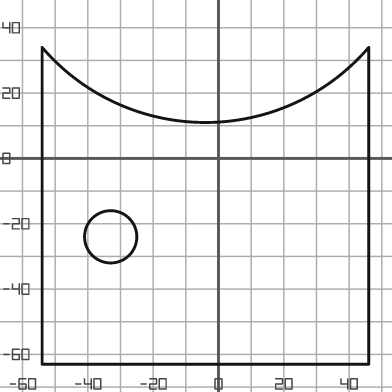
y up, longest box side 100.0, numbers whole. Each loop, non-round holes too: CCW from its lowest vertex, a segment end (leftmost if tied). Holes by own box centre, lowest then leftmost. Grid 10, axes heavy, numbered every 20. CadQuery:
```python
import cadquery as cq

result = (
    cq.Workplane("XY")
    .moveTo(-54.0, -63.0)
    .lineTo(46.0, -63.0)
    .lineTo(46.0, 34.0)
    .threePointArc((-4.0, 11.0), (-54.0, 34.0))
    .close()
    .moveTo(-33.0, -24.0)
    .circle(8.0)
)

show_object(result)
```